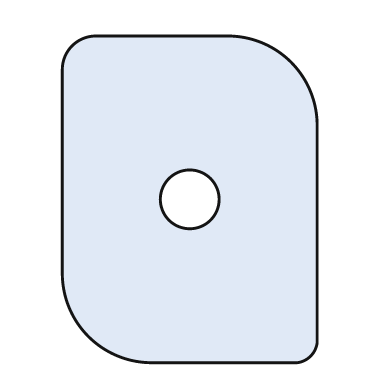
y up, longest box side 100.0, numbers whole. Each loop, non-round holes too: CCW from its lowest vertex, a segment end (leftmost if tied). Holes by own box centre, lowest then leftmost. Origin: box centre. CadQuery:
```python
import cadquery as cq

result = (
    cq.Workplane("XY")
    .moveTo(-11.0, -50.0)
    .lineTo(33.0, -50.0)
    .threePointArc((37.0, -48.0), (39.0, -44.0))
    .lineTo(39.0, 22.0)
    .threePointArc((31.0, 42.0), (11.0, 50.0))
    .lineTo(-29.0, 50.0)
    .threePointArc((-36.0, 47.0), (-39.0, 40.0))
    .lineTo(-39.0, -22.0)
    .threePointArc((-31.0, -42.0), (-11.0, -50.0))
    .close()
    .moveTo(0.0, 0.0)
    .circle(9.0)
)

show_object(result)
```